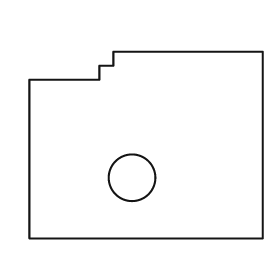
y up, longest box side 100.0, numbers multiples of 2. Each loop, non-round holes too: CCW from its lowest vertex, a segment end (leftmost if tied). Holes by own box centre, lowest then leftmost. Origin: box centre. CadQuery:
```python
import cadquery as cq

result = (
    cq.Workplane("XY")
    .moveTo(-50.0, -40.0)
    .lineTo(50.0, -40.0)
    .lineTo(50.0, 40.0)
    .lineTo(-14.0, 40.0)
    .lineTo(-14.0, 34.0)
    .lineTo(-20.0, 34.0)
    .lineTo(-20.0, 28.0)
    .lineTo(-50.0, 28.0)
    .close()
    .moveTo(-6.0, -14.0)
    .circle(10.0)
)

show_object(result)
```